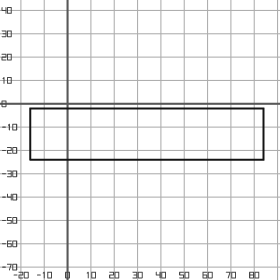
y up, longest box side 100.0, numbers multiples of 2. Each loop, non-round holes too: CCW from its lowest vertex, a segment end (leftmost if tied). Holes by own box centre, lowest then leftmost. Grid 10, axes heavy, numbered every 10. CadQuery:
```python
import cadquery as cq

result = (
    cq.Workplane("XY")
    .moveTo(-16.0, -24.0)
    .lineTo(84.0, -24.0)
    .lineTo(84.0, -2.0)
    .lineTo(-16.0, -2.0)
    .close()
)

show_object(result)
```